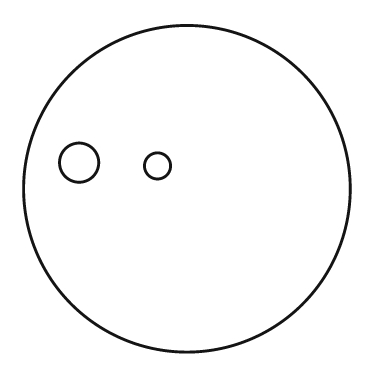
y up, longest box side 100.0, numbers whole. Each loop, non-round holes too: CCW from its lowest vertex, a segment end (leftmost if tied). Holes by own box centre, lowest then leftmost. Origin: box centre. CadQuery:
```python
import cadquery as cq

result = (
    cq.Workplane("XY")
    .moveTo(0.0, 0.0)
    .circle(50.0)
    .moveTo(-9.0, 7.0)
    .circle(4.0)
    .moveTo(-33.0, 8.0)
    .circle(6.0)
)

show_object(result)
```